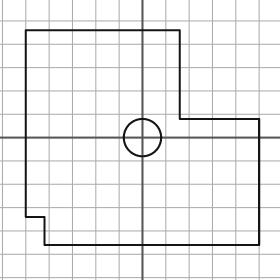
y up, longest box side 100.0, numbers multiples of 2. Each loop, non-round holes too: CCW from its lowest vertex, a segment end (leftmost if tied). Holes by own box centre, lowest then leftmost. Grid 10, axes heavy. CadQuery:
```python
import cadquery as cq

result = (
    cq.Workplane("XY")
    .moveTo(-42.0, -46.0)
    .lineTo(50.0, -46.0)
    .lineTo(50.0, 8.0)
    .lineTo(16.0, 8.0)
    .lineTo(16.0, 46.0)
    .lineTo(-50.0, 46.0)
    .lineTo(-50.0, -34.0)
    .lineTo(-42.0, -34.0)
    .close()
    .moveTo(0.0, 0.0)
    .circle(8.0)
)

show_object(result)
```